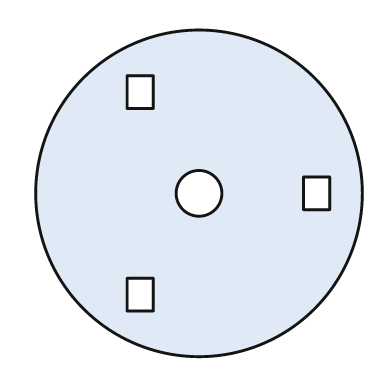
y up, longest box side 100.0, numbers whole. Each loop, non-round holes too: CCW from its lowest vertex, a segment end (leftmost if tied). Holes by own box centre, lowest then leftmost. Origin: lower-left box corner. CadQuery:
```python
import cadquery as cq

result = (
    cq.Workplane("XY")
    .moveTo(50.0, 50.0)
    .circle(50.0)
    .moveTo(28.0, 14.0)
    .lineTo(36.0, 14.0)
    .lineTo(36.0, 24.0)
    .lineTo(28.0, 24.0)
    .close()
    .moveTo(50.0, 50.0)
    .circle(7.0)
    .moveTo(82.0, 45.0)
    .lineTo(90.0, 45.0)
    .lineTo(90.0, 55.0)
    .lineTo(82.0, 55.0)
    .close()
    .moveTo(28.0, 76.0)
    .lineTo(36.0, 76.0)
    .lineTo(36.0, 86.0)
    .lineTo(28.0, 86.0)
    .close()
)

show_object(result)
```